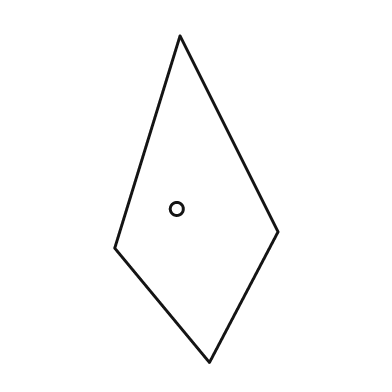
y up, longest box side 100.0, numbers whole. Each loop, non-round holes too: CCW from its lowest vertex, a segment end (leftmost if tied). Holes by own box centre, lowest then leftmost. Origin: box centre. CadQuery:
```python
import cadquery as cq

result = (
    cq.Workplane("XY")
    .moveTo(4.0, -50.0)
    .lineTo(25.0, -10.0)
    .lineTo(-5.0, 50.0)
    .lineTo(-25.0, -15.0)
    .close()
    .moveTo(-6.0, -3.0)
    .circle(2.0)
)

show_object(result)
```